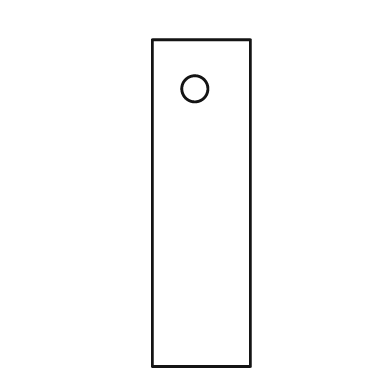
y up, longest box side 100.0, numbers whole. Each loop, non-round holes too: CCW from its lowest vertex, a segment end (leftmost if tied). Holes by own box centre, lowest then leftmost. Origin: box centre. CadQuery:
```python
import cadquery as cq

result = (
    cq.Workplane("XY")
    .moveTo(-15.0, -50.0)
    .lineTo(15.0, -50.0)
    .lineTo(15.0, 50.0)
    .lineTo(-15.0, 50.0)
    .close()
    .moveTo(-2.0, 35.0)
    .circle(4.0)
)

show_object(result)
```